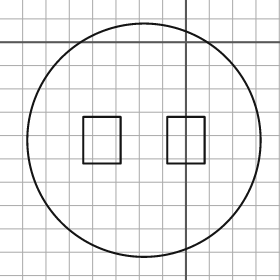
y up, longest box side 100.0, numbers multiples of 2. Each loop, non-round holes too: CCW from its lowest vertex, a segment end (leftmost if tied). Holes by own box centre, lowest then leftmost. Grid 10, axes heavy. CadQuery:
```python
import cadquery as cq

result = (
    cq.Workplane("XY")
    .moveTo(-18.0, -42.0)
    .circle(50.0)
    .moveTo(-44.0, -52.0)
    .lineTo(-28.0, -52.0)
    .lineTo(-28.0, -32.0)
    .lineTo(-44.0, -32.0)
    .close()
    .moveTo(-8.0, -52.0)
    .lineTo(8.0, -52.0)
    .lineTo(8.0, -32.0)
    .lineTo(-8.0, -32.0)
    .close()
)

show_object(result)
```